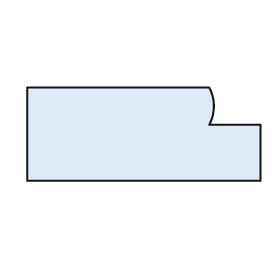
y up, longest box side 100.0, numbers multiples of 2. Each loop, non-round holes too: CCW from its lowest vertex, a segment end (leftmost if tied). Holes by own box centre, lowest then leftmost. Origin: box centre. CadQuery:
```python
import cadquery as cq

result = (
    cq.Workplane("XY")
    .moveTo(-50.0, -20.0)
    .lineTo(50.0, -20.0)
    .lineTo(50.0, 4.0)
    .lineTo(28.0, 4.0)
    .threePointArc((30.0, 12.0), (28.0, 20.0))
    .lineTo(-50.0, 20.0)
    .close()
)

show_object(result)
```